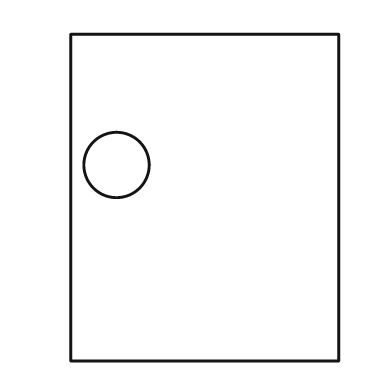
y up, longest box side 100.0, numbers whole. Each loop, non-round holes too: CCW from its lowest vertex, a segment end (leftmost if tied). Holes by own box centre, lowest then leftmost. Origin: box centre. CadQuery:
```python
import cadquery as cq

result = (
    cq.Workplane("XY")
    .moveTo(-41.0, -50.0)
    .lineTo(41.0, -50.0)
    .lineTo(41.0, 50.0)
    .lineTo(-41.0, 50.0)
    .close()
    .moveTo(-27.0, 10.0)
    .circle(10.0)
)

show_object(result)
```